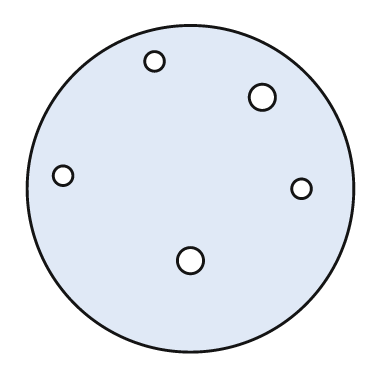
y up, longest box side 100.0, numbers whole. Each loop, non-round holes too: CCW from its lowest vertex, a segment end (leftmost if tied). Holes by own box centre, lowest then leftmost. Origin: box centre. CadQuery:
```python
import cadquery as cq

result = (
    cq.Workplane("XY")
    .moveTo(0.0, 0.0)
    .circle(50.0)
    .moveTo(0.0, -22.0)
    .circle(4.0)
    .moveTo(34.0, 0.0)
    .circle(3.0)
    .moveTo(-39.0, 4.0)
    .circle(3.0)
    .moveTo(22.0, 28.0)
    .circle(4.0)
    .moveTo(-11.0, 39.0)
    .circle(3.0)
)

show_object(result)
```